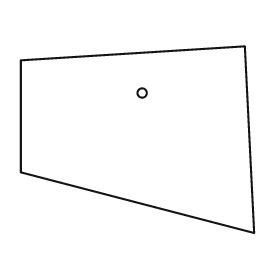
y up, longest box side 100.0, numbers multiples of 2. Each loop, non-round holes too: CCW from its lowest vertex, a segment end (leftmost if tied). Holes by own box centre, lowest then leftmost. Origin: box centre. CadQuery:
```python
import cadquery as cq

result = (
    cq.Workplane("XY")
    .moveTo(50.0, -40.0)
    .lineTo(46.0, 40.0)
    .lineTo(-50.0, 34.0)
    .lineTo(-50.0, -14.0)
    .close()
    .moveTo(2.0, 20.0)
    .circle(2.0)
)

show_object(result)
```